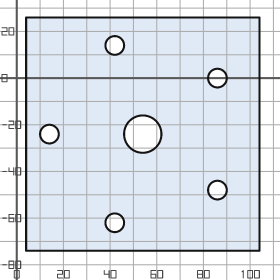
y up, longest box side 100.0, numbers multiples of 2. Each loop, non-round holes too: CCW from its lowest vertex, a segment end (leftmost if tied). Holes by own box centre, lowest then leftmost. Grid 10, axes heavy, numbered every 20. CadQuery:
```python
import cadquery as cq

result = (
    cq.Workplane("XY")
    .moveTo(4.0, -74.0)
    .lineTo(104.0, -74.0)
    .lineTo(104.0, 26.0)
    .lineTo(4.0, 26.0)
    .close()
    .moveTo(42.0, -62.0)
    .circle(4.0)
    .moveTo(86.0, -48.0)
    .circle(4.0)
    .moveTo(14.0, -24.0)
    .circle(4.0)
    .moveTo(54.0, -24.0)
    .circle(8.0)
    .moveTo(86.0, 0.0)
    .circle(4.0)
    .moveTo(42.0, 14.0)
    .circle(4.0)
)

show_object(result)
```